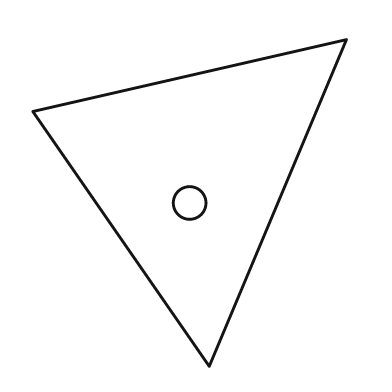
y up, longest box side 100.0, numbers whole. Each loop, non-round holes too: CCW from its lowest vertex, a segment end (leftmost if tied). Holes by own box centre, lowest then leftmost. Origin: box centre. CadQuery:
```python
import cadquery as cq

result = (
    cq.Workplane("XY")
    .moveTo(6.0, -50.0)
    .lineTo(48.0, 50.0)
    .lineTo(-48.0, 28.0)
    .close()
    .moveTo(0.0, 0.0)
    .circle(5.0)
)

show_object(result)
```